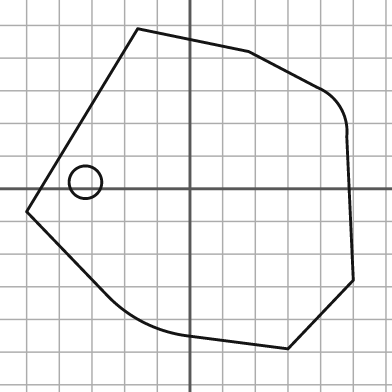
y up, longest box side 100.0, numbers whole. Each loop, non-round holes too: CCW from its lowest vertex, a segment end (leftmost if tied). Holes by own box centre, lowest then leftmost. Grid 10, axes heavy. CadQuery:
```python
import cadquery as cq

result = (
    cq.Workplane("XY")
    .moveTo(30.0, -49.0)
    .lineTo(50.0, -28.0)
    .lineTo(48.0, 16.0)
    .threePointArc((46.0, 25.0), (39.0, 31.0))
    .lineTo(18.0, 42.0)
    .lineTo(-16.0, 49.0)
    .lineTo(-50.0, -7.0)
    .lineTo(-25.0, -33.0)
    .threePointArc((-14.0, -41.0), (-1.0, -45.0))
    .close()
    .moveTo(-32.0, 2.0)
    .circle(5.0)
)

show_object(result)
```